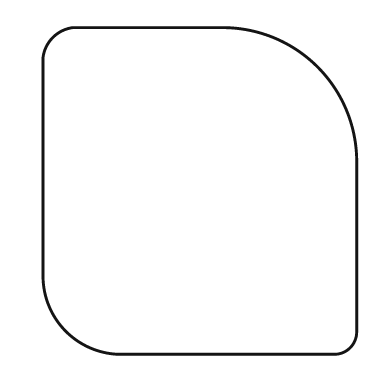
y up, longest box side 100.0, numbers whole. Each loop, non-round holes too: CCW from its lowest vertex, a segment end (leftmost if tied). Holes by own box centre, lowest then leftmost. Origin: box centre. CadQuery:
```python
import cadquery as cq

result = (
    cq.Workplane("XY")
    .moveTo(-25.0, -50.0)
    .lineTo(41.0, -50.0)
    .threePointArc((46.0, -48.0), (48.0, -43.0))
    .lineTo(48.0, 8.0)
    .threePointArc((36.0, 38.0), (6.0, 50.0))
    .lineTo(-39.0, 50.0)
    .threePointArc((-45.0, 47.0), (-48.0, 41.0))
    .lineTo(-48.0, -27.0)
    .threePointArc((-41.0, -43.0), (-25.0, -50.0))
    .close()
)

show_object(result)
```